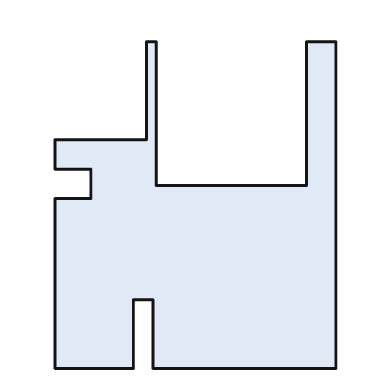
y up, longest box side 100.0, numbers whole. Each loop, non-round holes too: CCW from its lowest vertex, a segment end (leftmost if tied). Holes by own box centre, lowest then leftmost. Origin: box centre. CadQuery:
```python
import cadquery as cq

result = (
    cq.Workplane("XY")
    .moveTo(-43.0, -50.0)
    .lineTo(-19.0, -50.0)
    .lineTo(-19.0, -29.0)
    .lineTo(-13.0, -29.0)
    .lineTo(-13.0, -50.0)
    .lineTo(43.0, -50.0)
    .lineTo(43.0, 50.0)
    .lineTo(34.0, 50.0)
    .lineTo(34.0, 6.0)
    .lineTo(-12.0, 6.0)
    .lineTo(-12.0, 50.0)
    .lineTo(-15.0, 50.0)
    .lineTo(-15.0, 20.0)
    .lineTo(-43.0, 20.0)
    .lineTo(-43.0, 11.0)
    .lineTo(-32.0, 11.0)
    .lineTo(-32.0, 2.0)
    .lineTo(-43.0, 2.0)
    .close()
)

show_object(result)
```